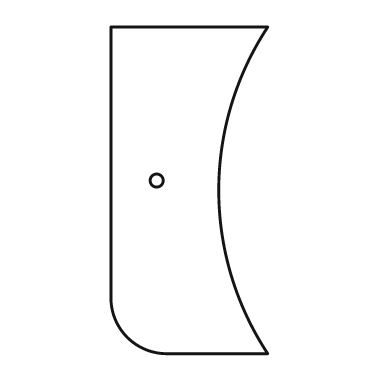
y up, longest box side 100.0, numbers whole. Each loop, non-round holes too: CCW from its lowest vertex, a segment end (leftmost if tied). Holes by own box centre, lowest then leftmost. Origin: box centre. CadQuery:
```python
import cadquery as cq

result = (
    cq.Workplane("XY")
    .moveTo(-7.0, -50.0)
    .lineTo(24.0, -50.0)
    .threePointArc((9.0, 0.0), (24.0, 50.0))
    .lineTo(-24.0, 50.0)
    .lineTo(-24.0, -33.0)
    .threePointArc((-19.0, -45.0), (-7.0, -50.0))
    .close()
    .moveTo(-10.0, 3.0)
    .circle(2.0)
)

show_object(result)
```